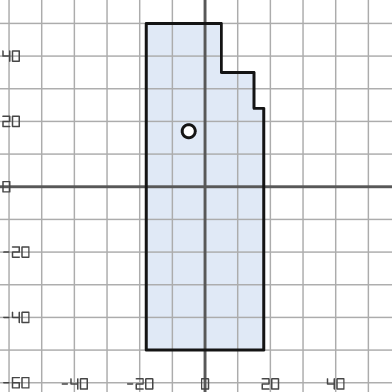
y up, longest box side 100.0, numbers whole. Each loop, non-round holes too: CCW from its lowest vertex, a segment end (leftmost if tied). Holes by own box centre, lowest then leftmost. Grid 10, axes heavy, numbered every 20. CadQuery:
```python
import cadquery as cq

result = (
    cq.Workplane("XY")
    .moveTo(-18.0, -50.0)
    .lineTo(18.0, -50.0)
    .lineTo(18.0, 24.0)
    .lineTo(15.0, 24.0)
    .lineTo(15.0, 35.0)
    .lineTo(5.0, 35.0)
    .lineTo(5.0, 50.0)
    .lineTo(-18.0, 50.0)
    .close()
    .moveTo(-5.0, 17.0)
    .circle(2.0)
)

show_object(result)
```